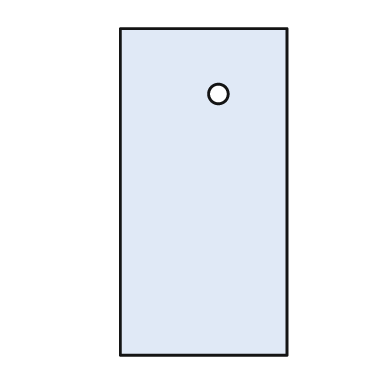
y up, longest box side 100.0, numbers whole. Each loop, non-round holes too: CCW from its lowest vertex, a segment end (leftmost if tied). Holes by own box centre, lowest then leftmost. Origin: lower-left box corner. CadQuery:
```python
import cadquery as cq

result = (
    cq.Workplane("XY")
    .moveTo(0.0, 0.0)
    .lineTo(51.0, 0.0)
    .lineTo(51.0, 100.0)
    .lineTo(0.0, 100.0)
    .close()
    .moveTo(30.0, 80.0)
    .circle(3.0)
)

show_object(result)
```